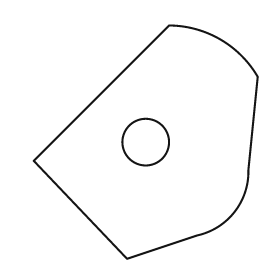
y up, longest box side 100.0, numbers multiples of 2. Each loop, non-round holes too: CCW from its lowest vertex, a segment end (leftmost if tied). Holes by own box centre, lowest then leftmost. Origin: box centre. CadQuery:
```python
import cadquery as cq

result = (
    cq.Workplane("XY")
    .moveTo(-8.0, -50.0)
    .lineTo(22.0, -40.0)
    .threePointArc((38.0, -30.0), (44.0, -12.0))
    .lineTo(48.0, 28.0)
    .threePointArc((32.0, 44.0), (10.0, 50.0))
    .lineTo(-48.0, -8.0)
    .close()
    .moveTo(0.0, 0.0)
    .circle(10.0)
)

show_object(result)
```